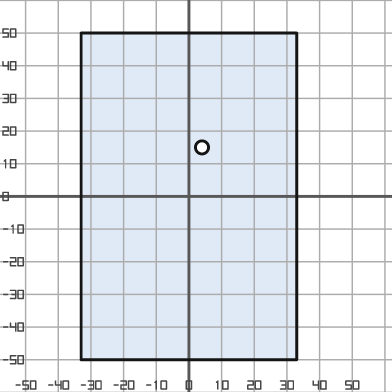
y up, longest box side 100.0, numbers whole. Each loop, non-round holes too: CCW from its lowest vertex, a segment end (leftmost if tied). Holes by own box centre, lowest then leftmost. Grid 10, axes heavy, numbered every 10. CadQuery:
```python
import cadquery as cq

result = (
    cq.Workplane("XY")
    .moveTo(-33.0, -50.0)
    .lineTo(33.0, -50.0)
    .lineTo(33.0, 50.0)
    .lineTo(-33.0, 50.0)
    .close()
    .moveTo(4.0, 15.0)
    .circle(2.0)
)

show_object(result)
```